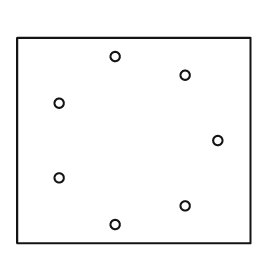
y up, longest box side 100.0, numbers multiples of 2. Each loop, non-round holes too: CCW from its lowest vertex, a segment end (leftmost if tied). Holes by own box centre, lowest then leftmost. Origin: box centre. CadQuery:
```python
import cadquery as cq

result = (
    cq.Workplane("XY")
    .moveTo(-50.0, -44.0)
    .lineTo(50.0, -44.0)
    .lineTo(50.0, 44.0)
    .lineTo(-50.0, 44.0)
    .close()
    .moveTo(-8.0, -36.0)
    .circle(2.0)
    .moveTo(22.0, -28.0)
    .circle(2.0)
    .moveTo(-32.0, -16.0)
    .circle(2.0)
    .moveTo(36.0, 0.0)
    .circle(2.0)
    .moveTo(-32.0, 16.0)
    .circle(2.0)
    .moveTo(22.0, 28.0)
    .circle(2.0)
    .moveTo(-8.0, 36.0)
    .circle(2.0)
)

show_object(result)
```